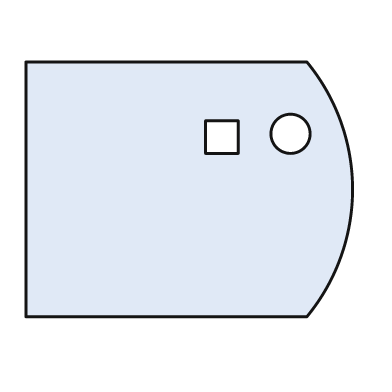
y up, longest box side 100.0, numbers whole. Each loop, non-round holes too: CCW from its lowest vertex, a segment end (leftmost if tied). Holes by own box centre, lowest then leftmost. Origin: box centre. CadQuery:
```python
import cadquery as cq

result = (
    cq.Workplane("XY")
    .moveTo(-50.0, -39.0)
    .lineTo(36.0, -39.0)
    .threePointArc((50.0, 0.0), (36.0, 39.0))
    .lineTo(-50.0, 39.0)
    .close()
    .moveTo(5.0, 11.0)
    .lineTo(15.0, 11.0)
    .lineTo(15.0, 21.0)
    .lineTo(5.0, 21.0)
    .close()
    .moveTo(31.0, 17.0)
    .circle(6.0)
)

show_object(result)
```